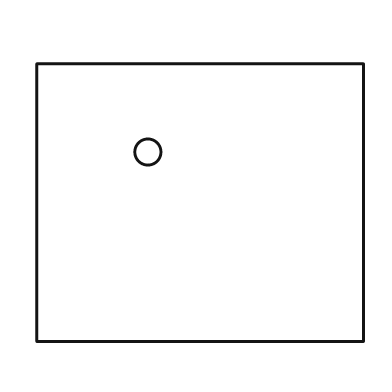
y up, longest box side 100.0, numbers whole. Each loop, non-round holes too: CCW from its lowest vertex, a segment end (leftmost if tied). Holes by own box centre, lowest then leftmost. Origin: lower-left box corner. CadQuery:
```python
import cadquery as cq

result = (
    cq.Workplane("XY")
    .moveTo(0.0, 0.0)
    .lineTo(100.0, 0.0)
    .lineTo(100.0, 85.0)
    .lineTo(0.0, 85.0)
    .close()
    .moveTo(34.0, 58.0)
    .circle(4.0)
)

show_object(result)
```